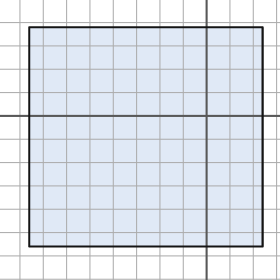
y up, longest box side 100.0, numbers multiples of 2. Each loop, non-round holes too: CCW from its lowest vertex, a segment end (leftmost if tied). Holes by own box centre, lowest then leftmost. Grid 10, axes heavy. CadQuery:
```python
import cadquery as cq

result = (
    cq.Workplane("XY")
    .moveTo(-76.0, -56.0)
    .lineTo(24.0, -56.0)
    .lineTo(24.0, 38.0)
    .lineTo(-76.0, 38.0)
    .close()
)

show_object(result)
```